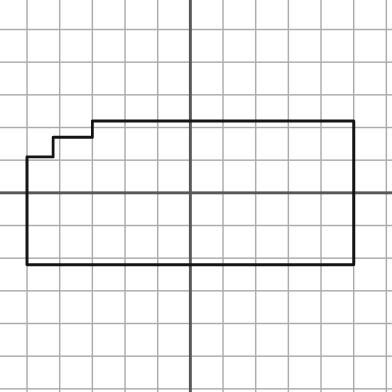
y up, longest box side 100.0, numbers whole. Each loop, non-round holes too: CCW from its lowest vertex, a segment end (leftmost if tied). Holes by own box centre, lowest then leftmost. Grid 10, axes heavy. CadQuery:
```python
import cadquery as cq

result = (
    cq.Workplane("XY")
    .moveTo(-50.0, -22.0)
    .lineTo(50.0, -22.0)
    .lineTo(50.0, 22.0)
    .lineTo(-30.0, 22.0)
    .lineTo(-30.0, 17.0)
    .lineTo(-42.0, 17.0)
    .lineTo(-42.0, 11.0)
    .lineTo(-50.0, 11.0)
    .close()
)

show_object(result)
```